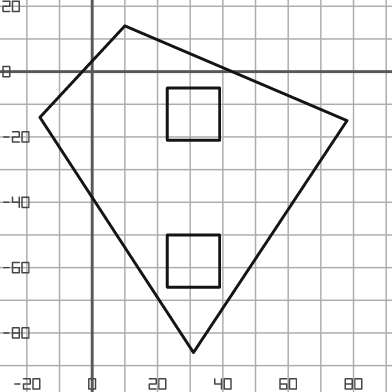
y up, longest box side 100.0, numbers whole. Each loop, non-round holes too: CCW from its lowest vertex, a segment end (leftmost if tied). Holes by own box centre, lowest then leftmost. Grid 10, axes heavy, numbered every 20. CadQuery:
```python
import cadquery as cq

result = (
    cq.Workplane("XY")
    .moveTo(31.0, -86.0)
    .lineTo(78.0, -15.0)
    .lineTo(10.0, 14.0)
    .lineTo(-16.0, -14.0)
    .close()
    .moveTo(23.0, -66.0)
    .lineTo(39.0, -66.0)
    .lineTo(39.0, -50.0)
    .lineTo(23.0, -50.0)
    .close()
    .moveTo(23.0, -21.0)
    .lineTo(39.0, -21.0)
    .lineTo(39.0, -5.0)
    .lineTo(23.0, -5.0)
    .close()
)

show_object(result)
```